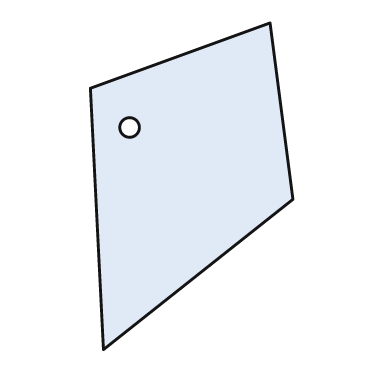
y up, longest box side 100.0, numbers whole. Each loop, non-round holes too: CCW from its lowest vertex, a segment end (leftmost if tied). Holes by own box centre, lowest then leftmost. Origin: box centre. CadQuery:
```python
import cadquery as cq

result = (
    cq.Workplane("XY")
    .moveTo(-27.0, -50.0)
    .lineTo(31.0, -4.0)
    .lineTo(24.0, 50.0)
    .lineTo(-31.0, 30.0)
    .close()
    .moveTo(-19.0, 18.0)
    .circle(3.0)
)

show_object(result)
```